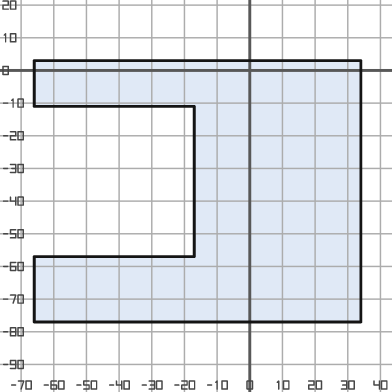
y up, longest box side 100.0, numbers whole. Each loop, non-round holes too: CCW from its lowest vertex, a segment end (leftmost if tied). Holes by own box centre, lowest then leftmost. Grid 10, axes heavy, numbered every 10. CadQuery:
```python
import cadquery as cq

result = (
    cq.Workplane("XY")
    .moveTo(-66.0, -77.0)
    .lineTo(34.0, -77.0)
    .lineTo(34.0, 3.0)
    .lineTo(-66.0, 3.0)
    .lineTo(-66.0, -11.0)
    .lineTo(-17.0, -11.0)
    .lineTo(-17.0, -57.0)
    .lineTo(-66.0, -57.0)
    .close()
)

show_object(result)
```